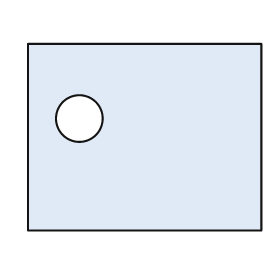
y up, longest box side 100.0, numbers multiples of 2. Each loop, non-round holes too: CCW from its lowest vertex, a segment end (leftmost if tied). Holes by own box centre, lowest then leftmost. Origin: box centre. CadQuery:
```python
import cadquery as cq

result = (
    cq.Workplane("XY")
    .moveTo(-50.0, -40.0)
    .lineTo(50.0, -40.0)
    .lineTo(50.0, 40.0)
    .lineTo(-50.0, 40.0)
    .close()
    .moveTo(-28.0, 8.0)
    .circle(10.0)
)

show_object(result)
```